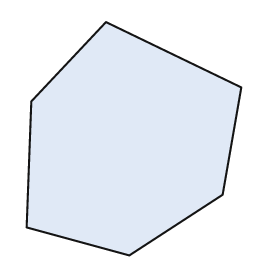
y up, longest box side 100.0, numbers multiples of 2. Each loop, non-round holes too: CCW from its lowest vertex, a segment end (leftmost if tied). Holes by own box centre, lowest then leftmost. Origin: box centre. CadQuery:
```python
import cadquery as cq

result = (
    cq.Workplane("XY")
    .moveTo(-2.0, -50.0)
    .lineTo(38.0, -24.0)
    .lineTo(46.0, 22.0)
    .lineTo(-12.0, 50.0)
    .lineTo(-44.0, 16.0)
    .lineTo(-46.0, -38.0)
    .close()
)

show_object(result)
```